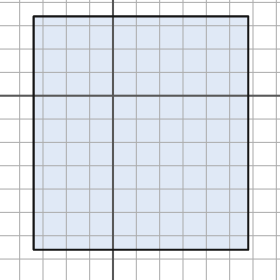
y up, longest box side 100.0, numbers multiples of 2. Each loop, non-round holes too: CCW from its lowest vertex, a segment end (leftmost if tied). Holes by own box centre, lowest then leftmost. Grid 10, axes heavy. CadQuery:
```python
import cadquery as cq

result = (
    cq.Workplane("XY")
    .moveTo(-34.0, -66.0)
    .lineTo(58.0, -66.0)
    .lineTo(58.0, 34.0)
    .lineTo(-34.0, 34.0)
    .close()
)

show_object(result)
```